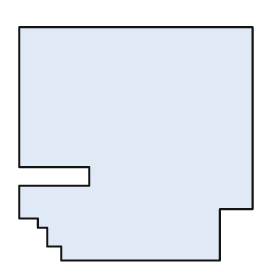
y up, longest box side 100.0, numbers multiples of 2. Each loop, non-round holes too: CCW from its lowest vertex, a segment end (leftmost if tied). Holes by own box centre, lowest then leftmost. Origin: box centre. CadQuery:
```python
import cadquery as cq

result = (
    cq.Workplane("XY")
    .moveTo(-32.0, -50.0)
    .lineTo(36.0, -50.0)
    .lineTo(36.0, -28.0)
    .lineTo(50.0, -28.0)
    .lineTo(50.0, 50.0)
    .lineTo(-50.0, 50.0)
    .lineTo(-50.0, -10.0)
    .lineTo(-20.0, -10.0)
    .lineTo(-20.0, -18.0)
    .lineTo(-50.0, -18.0)
    .lineTo(-50.0, -32.0)
    .lineTo(-42.0, -32.0)
    .lineTo(-42.0, -36.0)
    .lineTo(-38.0, -36.0)
    .lineTo(-38.0, -44.0)
    .lineTo(-32.0, -44.0)
    .close()
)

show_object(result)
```